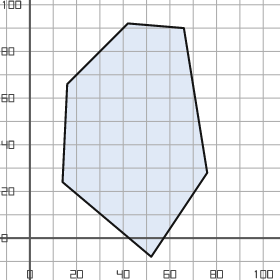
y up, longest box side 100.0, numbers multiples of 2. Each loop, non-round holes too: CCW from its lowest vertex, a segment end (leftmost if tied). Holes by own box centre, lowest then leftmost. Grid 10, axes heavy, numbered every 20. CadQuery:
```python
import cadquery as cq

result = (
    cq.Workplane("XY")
    .moveTo(52.0, -8.0)
    .lineTo(76.0, 28.0)
    .lineTo(66.0, 90.0)
    .lineTo(42.0, 92.0)
    .lineTo(16.0, 66.0)
    .lineTo(14.0, 24.0)
    .close()
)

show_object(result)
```